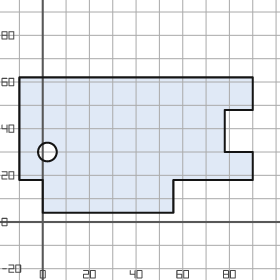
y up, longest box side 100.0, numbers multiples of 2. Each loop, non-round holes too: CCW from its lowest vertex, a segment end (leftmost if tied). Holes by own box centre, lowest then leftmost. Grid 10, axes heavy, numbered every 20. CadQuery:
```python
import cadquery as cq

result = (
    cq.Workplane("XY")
    .moveTo(0.0, 4.0)
    .lineTo(56.0, 4.0)
    .lineTo(56.0, 18.0)
    .lineTo(90.0, 18.0)
    .lineTo(90.0, 30.0)
    .lineTo(78.0, 30.0)
    .lineTo(78.0, 48.0)
    .lineTo(90.0, 48.0)
    .lineTo(90.0, 62.0)
    .lineTo(-10.0, 62.0)
    .lineTo(-10.0, 18.0)
    .lineTo(0.0, 18.0)
    .close()
    .moveTo(2.0, 30.0)
    .circle(4.0)
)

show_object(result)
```